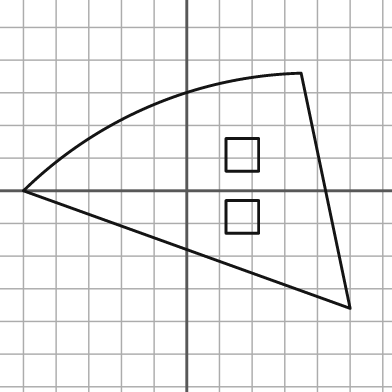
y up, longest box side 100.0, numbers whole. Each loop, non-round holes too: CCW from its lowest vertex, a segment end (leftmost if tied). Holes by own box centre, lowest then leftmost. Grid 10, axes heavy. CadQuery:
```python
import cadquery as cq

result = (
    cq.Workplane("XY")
    .moveTo(50.0, -36.0)
    .lineTo(35.0, 36.0)
    .threePointArc((-11.0, 26.0), (-50.0, 0.0))
    .close()
    .moveTo(12.0, -13.0)
    .lineTo(22.0, -13.0)
    .lineTo(22.0, -3.0)
    .lineTo(12.0, -3.0)
    .close()
    .moveTo(12.0, 6.0)
    .lineTo(22.0, 6.0)
    .lineTo(22.0, 16.0)
    .lineTo(12.0, 16.0)
    .close()
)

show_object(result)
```